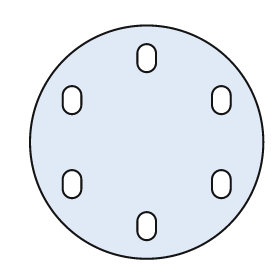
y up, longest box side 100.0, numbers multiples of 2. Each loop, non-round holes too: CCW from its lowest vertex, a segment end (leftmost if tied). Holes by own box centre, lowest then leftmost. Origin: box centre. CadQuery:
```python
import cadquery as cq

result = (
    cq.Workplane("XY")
    .moveTo(0.0, 0.0)
    .circle(50.0)
    .moveTo(-4.0, -38.0)
    .threePointArc((0.0, -42.0), (4.0, -38.0))
    .lineTo(4.0, -34.0)
    .threePointArc((0.0, -30.0), (-4.0, -34.0))
    .close()
    .moveTo(-36.0, -20.0)
    .threePointArc((-32.0, -24.0), (-28.0, -20.0))
    .lineTo(-28.0, -16.0)
    .threePointArc((-32.0, -12.0), (-36.0, -16.0))
    .close()
    .moveTo(28.0, -20.0)
    .threePointArc((32.0, -24.0), (36.0, -20.0))
    .lineTo(36.0, -16.0)
    .threePointArc((32.0, -12.0), (28.0, -16.0))
    .close()
    .moveTo(-36.0, 16.0)
    .threePointArc((-32.0, 12.0), (-28.0, 16.0))
    .lineTo(-28.0, 20.0)
    .threePointArc((-32.0, 24.0), (-36.0, 20.0))
    .close()
    .moveTo(28.0, 16.0)
    .threePointArc((32.0, 12.0), (36.0, 16.0))
    .lineTo(36.0, 20.0)
    .threePointArc((32.0, 24.0), (28.0, 20.0))
    .close()
    .moveTo(-4.0, 34.0)
    .threePointArc((0.0, 30.0), (4.0, 34.0))
    .lineTo(4.0, 38.0)
    .threePointArc((0.0, 42.0), (-4.0, 38.0))
    .close()
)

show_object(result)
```